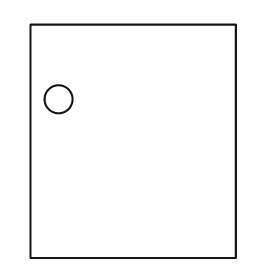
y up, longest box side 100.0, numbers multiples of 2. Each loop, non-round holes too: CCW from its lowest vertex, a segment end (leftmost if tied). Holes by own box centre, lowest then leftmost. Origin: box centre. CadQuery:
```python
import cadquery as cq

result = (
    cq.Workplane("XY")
    .moveTo(-44.0, -50.0)
    .lineTo(44.0, -50.0)
    .lineTo(44.0, 50.0)
    .lineTo(-44.0, 50.0)
    .close()
    .moveTo(-32.0, 18.0)
    .circle(6.0)
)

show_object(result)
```